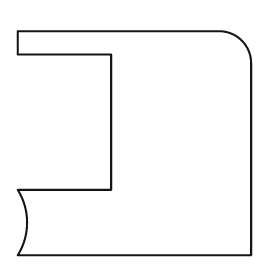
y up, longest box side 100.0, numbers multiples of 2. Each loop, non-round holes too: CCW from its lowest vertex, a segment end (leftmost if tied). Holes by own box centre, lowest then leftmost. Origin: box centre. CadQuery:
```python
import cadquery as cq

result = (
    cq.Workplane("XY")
    .moveTo(-50.0, -48.0)
    .lineTo(50.0, -48.0)
    .lineTo(50.0, 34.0)
    .threePointArc((46.0, 44.0), (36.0, 48.0))
    .lineTo(-50.0, 48.0)
    .lineTo(-50.0, 38.0)
    .lineTo(-10.0, 38.0)
    .lineTo(-10.0, -20.0)
    .lineTo(-50.0, -20.0)
    .threePointArc((-46.0, -34.0), (-50.0, -48.0))
    .close()
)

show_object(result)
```